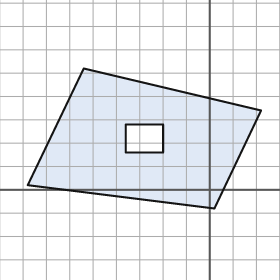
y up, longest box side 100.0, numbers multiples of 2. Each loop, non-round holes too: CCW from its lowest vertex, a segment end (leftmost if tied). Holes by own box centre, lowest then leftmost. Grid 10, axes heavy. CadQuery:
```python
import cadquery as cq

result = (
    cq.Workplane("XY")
    .moveTo(2.0, -8.0)
    .lineTo(22.0, 34.0)
    .lineTo(-54.0, 52.0)
    .lineTo(-78.0, 2.0)
    .close()
    .moveTo(-36.0, 16.0)
    .lineTo(-20.0, 16.0)
    .lineTo(-20.0, 28.0)
    .lineTo(-36.0, 28.0)
    .close()
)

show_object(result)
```